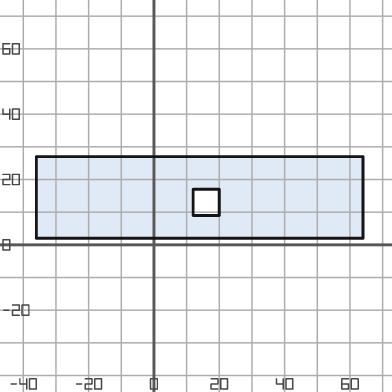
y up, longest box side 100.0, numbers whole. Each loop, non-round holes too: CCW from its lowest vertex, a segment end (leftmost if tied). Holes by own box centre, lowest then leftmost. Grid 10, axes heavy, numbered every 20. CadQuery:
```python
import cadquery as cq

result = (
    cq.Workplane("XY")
    .moveTo(-36.0, 2.0)
    .lineTo(64.0, 2.0)
    .lineTo(64.0, 27.0)
    .lineTo(-36.0, 27.0)
    .close()
    .moveTo(12.0, 9.0)
    .lineTo(20.0, 9.0)
    .lineTo(20.0, 17.0)
    .lineTo(12.0, 17.0)
    .close()
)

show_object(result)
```